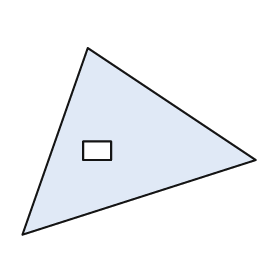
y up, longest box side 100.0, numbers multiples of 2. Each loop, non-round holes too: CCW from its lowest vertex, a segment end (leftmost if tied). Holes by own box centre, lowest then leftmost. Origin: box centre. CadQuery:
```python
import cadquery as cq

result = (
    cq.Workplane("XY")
    .moveTo(-50.0, -40.0)
    .lineTo(50.0, -8.0)
    .lineTo(-22.0, 40.0)
    .close()
    .moveTo(-24.0, -8.0)
    .lineTo(-12.0, -8.0)
    .lineTo(-12.0, 0.0)
    .lineTo(-24.0, 0.0)
    .close()
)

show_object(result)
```